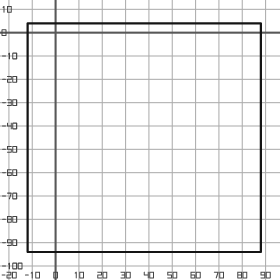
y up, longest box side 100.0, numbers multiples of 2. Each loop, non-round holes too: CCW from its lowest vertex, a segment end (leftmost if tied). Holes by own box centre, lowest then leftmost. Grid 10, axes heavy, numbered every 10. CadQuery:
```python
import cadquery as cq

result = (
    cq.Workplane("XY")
    .moveTo(-12.0, -94.0)
    .lineTo(88.0, -94.0)
    .lineTo(88.0, 4.0)
    .lineTo(-12.0, 4.0)
    .close()
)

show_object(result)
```